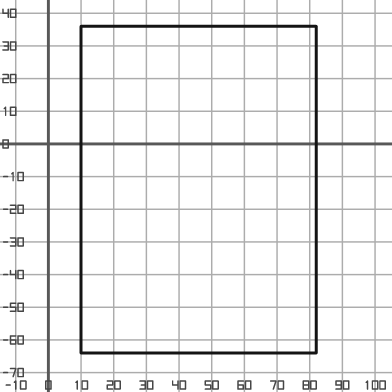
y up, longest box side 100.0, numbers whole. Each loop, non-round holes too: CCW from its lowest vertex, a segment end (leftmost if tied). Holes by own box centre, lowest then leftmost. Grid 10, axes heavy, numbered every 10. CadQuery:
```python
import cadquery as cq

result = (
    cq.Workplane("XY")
    .moveTo(10.0, -64.0)
    .lineTo(82.0, -64.0)
    .lineTo(82.0, 36.0)
    .lineTo(10.0, 36.0)
    .close()
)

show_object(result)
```